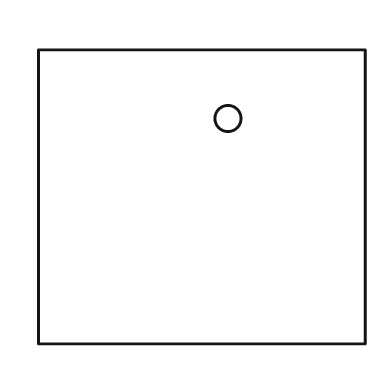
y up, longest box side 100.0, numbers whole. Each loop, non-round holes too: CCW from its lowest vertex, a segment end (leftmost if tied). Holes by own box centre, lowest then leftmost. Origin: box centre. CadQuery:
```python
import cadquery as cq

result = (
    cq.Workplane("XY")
    .moveTo(-50.0, -45.0)
    .lineTo(50.0, -45.0)
    .lineTo(50.0, 45.0)
    .lineTo(-50.0, 45.0)
    .close()
    .moveTo(8.0, 24.0)
    .circle(4.0)
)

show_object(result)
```